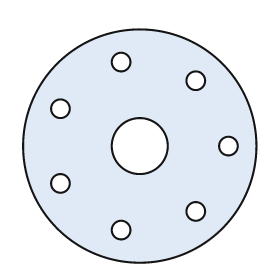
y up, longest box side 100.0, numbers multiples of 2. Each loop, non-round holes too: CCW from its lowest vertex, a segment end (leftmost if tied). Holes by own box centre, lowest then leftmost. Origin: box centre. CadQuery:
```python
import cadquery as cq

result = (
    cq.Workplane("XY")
    .moveTo(0.0, 0.0)
    .circle(50.0)
    .moveTo(-8.0, -36.0)
    .circle(4.0)
    .moveTo(24.0, -28.0)
    .circle(4.0)
    .moveTo(-34.0, -16.0)
    .circle(4.0)
    .moveTo(0.0, 0.0)
    .circle(12.0)
    .moveTo(38.0, 0.0)
    .circle(4.0)
    .moveTo(-34.0, 16.0)
    .circle(4.0)
    .moveTo(24.0, 28.0)
    .circle(4.0)
    .moveTo(-8.0, 36.0)
    .circle(4.0)
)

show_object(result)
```